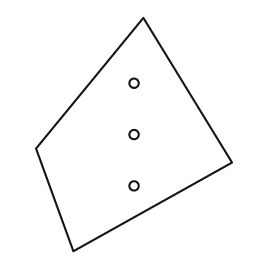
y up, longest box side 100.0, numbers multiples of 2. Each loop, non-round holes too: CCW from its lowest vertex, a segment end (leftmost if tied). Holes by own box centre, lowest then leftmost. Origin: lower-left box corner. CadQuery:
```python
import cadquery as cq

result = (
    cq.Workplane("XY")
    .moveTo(16.0, 0.0)
    .lineTo(84.0, 38.0)
    .lineTo(46.0, 100.0)
    .lineTo(0.0, 44.0)
    .close()
    .moveTo(42.0, 28.0)
    .circle(2.0)
    .moveTo(42.0, 50.0)
    .circle(2.0)
    .moveTo(42.0, 72.0)
    .circle(2.0)
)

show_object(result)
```